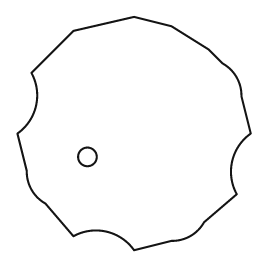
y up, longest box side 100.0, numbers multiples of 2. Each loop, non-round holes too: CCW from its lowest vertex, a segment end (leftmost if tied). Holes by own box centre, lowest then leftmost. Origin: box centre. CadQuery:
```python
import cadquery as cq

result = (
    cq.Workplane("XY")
    .moveTo(0.0, -50.0)
    .lineTo(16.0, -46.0)
    .threePointArc((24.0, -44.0), (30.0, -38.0))
    .lineTo(44.0, -26.0)
    .threePointArc((42.0, -12.0), (50.0, 0.0))
    .lineTo(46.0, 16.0)
    .threePointArc((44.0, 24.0), (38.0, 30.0))
    .lineTo(32.0, 36.0)
    .lineTo(16.0, 46.0)
    .lineTo(0.0, 50.0)
    .lineTo(-26.0, 44.0)
    .lineTo(-44.0, 26.0)
    .threePointArc((-42.0, 12.0), (-50.0, 0.0))
    .lineTo(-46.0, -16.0)
    .threePointArc((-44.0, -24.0), (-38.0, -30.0))
    .lineTo(-26.0, -44.0)
    .threePointArc((-12.0, -42.0), (0.0, -50.0))
    .close()
    .moveTo(-20.0, -10.0)
    .circle(4.0)
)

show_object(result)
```